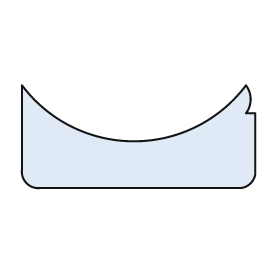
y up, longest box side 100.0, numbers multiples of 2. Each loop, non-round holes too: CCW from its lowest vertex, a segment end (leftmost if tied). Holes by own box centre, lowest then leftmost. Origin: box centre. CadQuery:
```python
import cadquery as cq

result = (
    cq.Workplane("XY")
    .moveTo(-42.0, -22.0)
    .lineTo(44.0, -22.0)
    .threePointArc((48.0, -20.0), (50.0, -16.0))
    .lineTo(50.0, 10.0)
    .lineTo(46.0, 10.0)
    .threePointArc((48.0, 16.0), (46.0, 22.0))
    .threePointArc((-2.0, -2.0), (-50.0, 22.0))
    .lineTo(-50.0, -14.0)
    .threePointArc((-48.0, -20.0), (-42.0, -22.0))
    .close()
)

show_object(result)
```